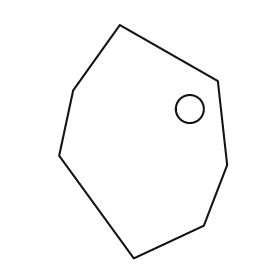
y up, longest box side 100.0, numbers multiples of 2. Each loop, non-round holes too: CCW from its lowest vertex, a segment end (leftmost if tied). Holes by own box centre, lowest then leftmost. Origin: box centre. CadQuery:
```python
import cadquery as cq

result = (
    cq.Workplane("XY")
    .moveTo(-4.0, -50.0)
    .lineTo(26.0, -36.0)
    .lineTo(36.0, -10.0)
    .lineTo(32.0, 26.0)
    .lineTo(-10.0, 50.0)
    .lineTo(-30.0, 22.0)
    .lineTo(-36.0, -6.0)
    .close()
    .moveTo(20.0, 14.0)
    .circle(6.0)
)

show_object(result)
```